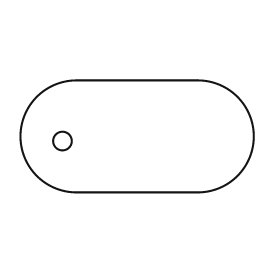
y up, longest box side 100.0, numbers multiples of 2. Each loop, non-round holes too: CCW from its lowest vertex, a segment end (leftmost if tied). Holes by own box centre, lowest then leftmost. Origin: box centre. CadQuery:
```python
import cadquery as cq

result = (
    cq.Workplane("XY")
    .moveTo(-26.0, -24.0)
    .lineTo(26.0, -24.0)
    .threePointArc((50.0, 0.0), (26.0, 24.0))
    .lineTo(-26.0, 24.0)
    .threePointArc((-50.0, 0.0), (-26.0, -24.0))
    .close()
    .moveTo(-32.0, -2.0)
    .circle(4.0)
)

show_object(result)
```